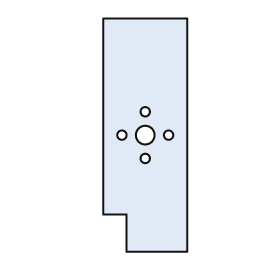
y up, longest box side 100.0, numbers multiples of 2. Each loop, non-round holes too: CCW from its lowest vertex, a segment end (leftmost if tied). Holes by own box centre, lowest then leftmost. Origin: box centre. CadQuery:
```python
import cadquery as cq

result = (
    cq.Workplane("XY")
    .moveTo(-8.0, -50.0)
    .lineTo(18.0, -50.0)
    .lineTo(18.0, 50.0)
    .lineTo(-18.0, 50.0)
    .lineTo(-18.0, -34.0)
    .lineTo(-8.0, -34.0)
    .close()
    .moveTo(0.0, -10.0)
    .circle(2.0)
    .moveTo(-10.0, 0.0)
    .circle(2.0)
    .moveTo(0.0, 0.0)
    .circle(4.0)
    .moveTo(10.0, 0.0)
    .circle(2.0)
    .moveTo(0.0, 10.0)
    .circle(2.0)
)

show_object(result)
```